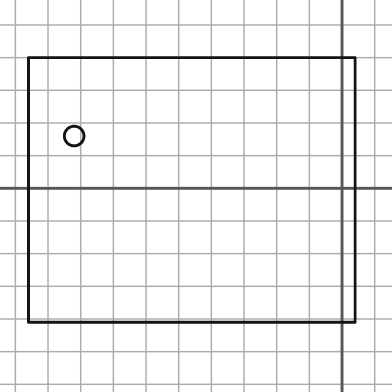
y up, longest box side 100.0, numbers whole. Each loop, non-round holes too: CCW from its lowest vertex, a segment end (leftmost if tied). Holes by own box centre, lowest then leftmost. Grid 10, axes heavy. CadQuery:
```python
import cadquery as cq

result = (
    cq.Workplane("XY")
    .moveTo(-96.0, -41.0)
    .lineTo(4.0, -41.0)
    .lineTo(4.0, 40.0)
    .lineTo(-96.0, 40.0)
    .close()
    .moveTo(-82.0, 16.0)
    .circle(3.0)
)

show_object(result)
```